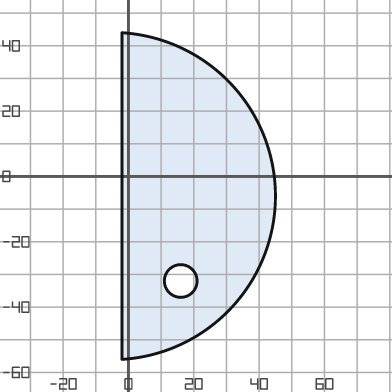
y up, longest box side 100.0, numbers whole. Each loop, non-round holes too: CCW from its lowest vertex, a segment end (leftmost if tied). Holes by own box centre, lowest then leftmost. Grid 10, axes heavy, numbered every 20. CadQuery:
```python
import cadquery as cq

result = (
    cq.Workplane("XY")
    .moveTo(-2.0, -56.0)
    .threePointArc((45.0, -6.0), (-2.0, 44.0))
    .close()
    .moveTo(16.0, -32.0)
    .circle(5.0)
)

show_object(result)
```